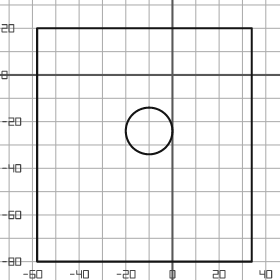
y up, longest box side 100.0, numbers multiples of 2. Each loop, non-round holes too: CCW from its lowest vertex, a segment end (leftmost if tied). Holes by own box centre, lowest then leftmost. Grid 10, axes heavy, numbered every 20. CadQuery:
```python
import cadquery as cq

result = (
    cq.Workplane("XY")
    .moveTo(-58.0, -80.0)
    .lineTo(34.0, -80.0)
    .lineTo(34.0, 20.0)
    .lineTo(-58.0, 20.0)
    .close()
    .moveTo(-10.0, -24.0)
    .circle(10.0)
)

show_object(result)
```